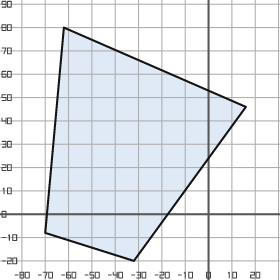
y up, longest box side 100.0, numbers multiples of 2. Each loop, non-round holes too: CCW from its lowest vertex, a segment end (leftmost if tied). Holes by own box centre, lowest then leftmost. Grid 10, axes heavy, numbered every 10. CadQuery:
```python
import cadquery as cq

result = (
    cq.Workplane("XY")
    .moveTo(-32.0, -20.0)
    .lineTo(16.0, 46.0)
    .lineTo(-62.0, 80.0)
    .lineTo(-70.0, -8.0)
    .close()
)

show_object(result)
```